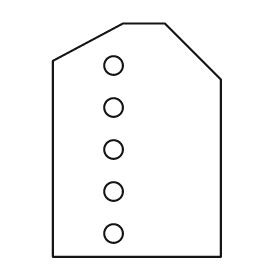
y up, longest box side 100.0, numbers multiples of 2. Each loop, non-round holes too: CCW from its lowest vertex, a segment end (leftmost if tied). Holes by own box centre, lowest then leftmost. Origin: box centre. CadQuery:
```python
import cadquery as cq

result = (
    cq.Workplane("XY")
    .moveTo(-36.0, -50.0)
    .lineTo(36.0, -50.0)
    .lineTo(36.0, 26.0)
    .lineTo(12.0, 50.0)
    .lineTo(-6.0, 50.0)
    .lineTo(-36.0, 34.0)
    .close()
    .moveTo(-10.0, -40.0)
    .circle(4.0)
    .moveTo(-10.0, -22.0)
    .circle(4.0)
    .moveTo(-10.0, -4.0)
    .circle(4.0)
    .moveTo(-10.0, 14.0)
    .circle(4.0)
    .moveTo(-10.0, 32.0)
    .circle(4.0)
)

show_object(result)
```